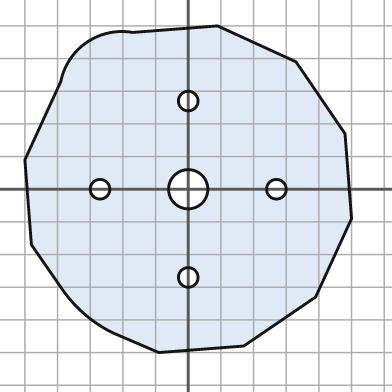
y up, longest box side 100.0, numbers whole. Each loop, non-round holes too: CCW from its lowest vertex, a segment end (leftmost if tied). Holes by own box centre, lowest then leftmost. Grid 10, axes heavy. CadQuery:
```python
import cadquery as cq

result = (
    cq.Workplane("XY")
    .moveTo(-9.0, -50.0)
    .lineTo(17.0, -48.0)
    .lineTo(39.0, -33.0)
    .lineTo(50.0, -9.0)
    .lineTo(48.0, 17.0)
    .lineTo(33.0, 39.0)
    .lineTo(9.0, 50.0)
    .lineTo(-17.0, 48.0)
    .threePointArc((-31.0, 45.0), (-39.0, 33.0))
    .lineTo(-50.0, 9.0)
    .lineTo(-48.0, -17.0)
    .lineTo(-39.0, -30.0)
    .threePointArc((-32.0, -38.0), (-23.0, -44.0))
    .close()
    .moveTo(0.0, -27.0)
    .circle(3.0)
    .moveTo(-27.0, 0.0)
    .circle(3.0)
    .moveTo(0.0, 0.0)
    .circle(6.0)
    .moveTo(27.0, 0.0)
    .circle(3.0)
    .moveTo(0.0, 27.0)
    .circle(3.0)
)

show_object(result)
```